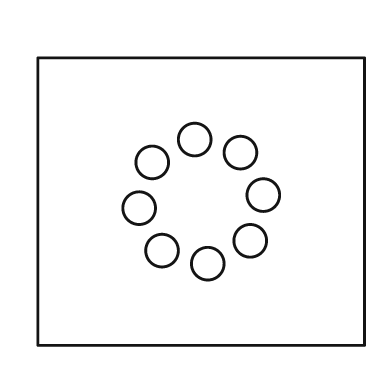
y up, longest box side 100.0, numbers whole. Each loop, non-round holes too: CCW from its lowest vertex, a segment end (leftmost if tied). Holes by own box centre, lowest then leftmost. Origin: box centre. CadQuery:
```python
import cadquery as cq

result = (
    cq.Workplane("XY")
    .moveTo(-50.0, -44.0)
    .lineTo(50.0, -44.0)
    .lineTo(50.0, 44.0)
    .lineTo(-50.0, 44.0)
    .close()
    .moveTo(2.0, -19.0)
    .circle(5.0)
    .moveTo(-12.0, -15.0)
    .circle(5.0)
    .moveTo(15.0, -12.0)
    .circle(5.0)
    .moveTo(-19.0, -2.0)
    .circle(5.0)
    .moveTo(19.0, 2.0)
    .circle(5.0)
    .moveTo(-15.0, 12.0)
    .circle(5.0)
    .moveTo(12.0, 15.0)
    .circle(5.0)
    .moveTo(-2.0, 19.0)
    .circle(5.0)
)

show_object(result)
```